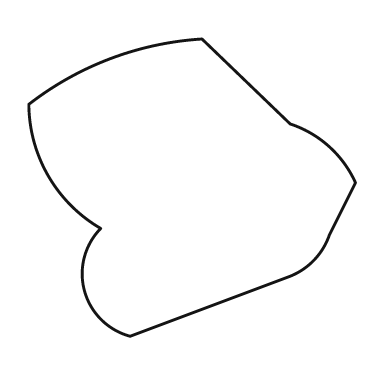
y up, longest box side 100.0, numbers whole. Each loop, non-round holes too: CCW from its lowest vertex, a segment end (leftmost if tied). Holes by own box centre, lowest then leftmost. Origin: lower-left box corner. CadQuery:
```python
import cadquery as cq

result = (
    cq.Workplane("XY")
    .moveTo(31.0, 0.0)
    .lineTo(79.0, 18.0)
    .threePointArc((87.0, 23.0), (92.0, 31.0))
    .lineTo(100.0, 47.0)
    .threePointArc((92.0, 58.0), (80.0, 65.0))
    .lineTo(53.0, 91.0)
    .threePointArc((25.0, 85.0), (0.0, 71.0))
    .threePointArc((6.0, 49.0), (22.0, 33.0))
    .threePointArc((17.0, 14.0), (31.0, 0.0))
    .close()
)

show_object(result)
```